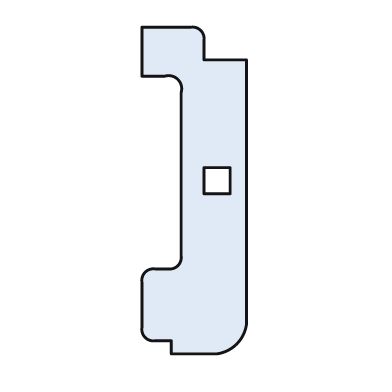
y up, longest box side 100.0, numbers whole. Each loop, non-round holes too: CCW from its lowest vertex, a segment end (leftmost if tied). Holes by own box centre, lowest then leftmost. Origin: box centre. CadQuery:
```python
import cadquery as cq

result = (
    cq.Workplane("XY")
    .moveTo(-7.0, -50.0)
    .lineTo(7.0, -50.0)
    .threePointArc((13.0, -47.0), (16.0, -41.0))
    .lineTo(16.0, 40.0)
    .lineTo(3.0, 40.0)
    .lineTo(3.0, 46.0)
    .threePointArc((2.0, 49.0), (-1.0, 50.0))
    .lineTo(-16.0, 50.0)
    .lineTo(-16.0, 35.0)
    .lineTo(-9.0, 35.0)
    .threePointArc((-5.0, 34.0), (-4.0, 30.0))
    .lineTo(-4.0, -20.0)
    .threePointArc((-5.0, -23.0), (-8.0, -24.0))
    .lineTo(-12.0, -24.0)
    .threePointArc((-15.0, -25.0), (-16.0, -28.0))
    .lineTo(-16.0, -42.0)
    .threePointArc((-15.0, -45.0), (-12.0, -46.0))
    .lineTo(-7.0, -46.0)
    .close()
    .moveTo(3.0, -1.0)
    .lineTo(11.0, -1.0)
    .lineTo(11.0, 7.0)
    .lineTo(3.0, 7.0)
    .close()
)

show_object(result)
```